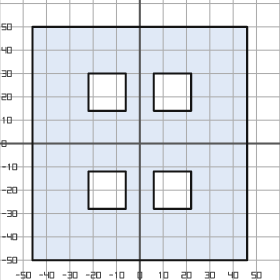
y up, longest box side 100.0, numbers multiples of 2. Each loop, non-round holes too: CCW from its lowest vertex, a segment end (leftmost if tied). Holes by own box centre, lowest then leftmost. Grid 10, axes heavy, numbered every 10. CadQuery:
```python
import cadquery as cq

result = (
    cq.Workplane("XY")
    .moveTo(-46.0, -50.0)
    .lineTo(46.0, -50.0)
    .lineTo(46.0, 50.0)
    .lineTo(-46.0, 50.0)
    .close()
    .moveTo(-22.0, -28.0)
    .lineTo(-6.0, -28.0)
    .lineTo(-6.0, -12.0)
    .lineTo(-22.0, -12.0)
    .close()
    .moveTo(6.0, -28.0)
    .lineTo(22.0, -28.0)
    .lineTo(22.0, -12.0)
    .lineTo(6.0, -12.0)
    .close()
    .moveTo(-22.0, 14.0)
    .lineTo(-6.0, 14.0)
    .lineTo(-6.0, 30.0)
    .lineTo(-22.0, 30.0)
    .close()
    .moveTo(6.0, 14.0)
    .lineTo(22.0, 14.0)
    .lineTo(22.0, 30.0)
    .lineTo(6.0, 30.0)
    .close()
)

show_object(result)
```